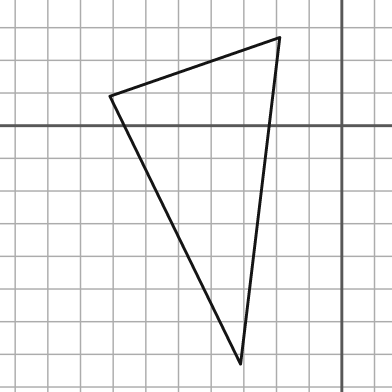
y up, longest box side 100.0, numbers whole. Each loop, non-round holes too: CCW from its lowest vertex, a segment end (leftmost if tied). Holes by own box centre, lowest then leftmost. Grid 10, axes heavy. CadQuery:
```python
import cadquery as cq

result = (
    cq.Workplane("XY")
    .moveTo(-31.0, -73.0)
    .lineTo(-19.0, 27.0)
    .lineTo(-71.0, 9.0)
    .close()
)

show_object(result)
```